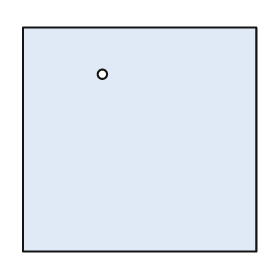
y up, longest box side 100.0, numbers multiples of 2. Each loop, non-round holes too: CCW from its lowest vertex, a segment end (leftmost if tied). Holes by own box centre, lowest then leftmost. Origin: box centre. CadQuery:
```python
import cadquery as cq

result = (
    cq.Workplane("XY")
    .moveTo(-50.0, -48.0)
    .lineTo(50.0, -48.0)
    .lineTo(50.0, 48.0)
    .lineTo(-50.0, 48.0)
    .close()
    .moveTo(-16.0, 28.0)
    .circle(2.0)
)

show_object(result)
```